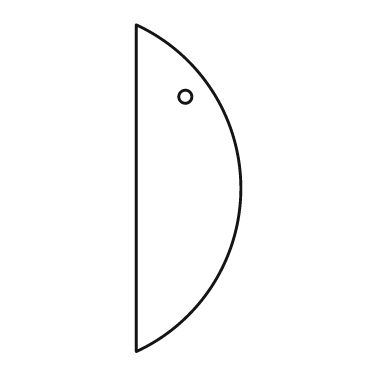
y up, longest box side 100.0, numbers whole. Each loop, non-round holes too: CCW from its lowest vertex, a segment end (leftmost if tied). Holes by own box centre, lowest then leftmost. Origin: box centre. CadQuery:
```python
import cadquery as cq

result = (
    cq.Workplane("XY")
    .moveTo(-16.0, -50.0)
    .threePointArc((16.0, 0.0), (-16.0, 50.0))
    .close()
    .moveTo(-1.0, 28.0)
    .circle(2.0)
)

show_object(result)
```